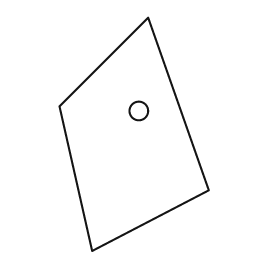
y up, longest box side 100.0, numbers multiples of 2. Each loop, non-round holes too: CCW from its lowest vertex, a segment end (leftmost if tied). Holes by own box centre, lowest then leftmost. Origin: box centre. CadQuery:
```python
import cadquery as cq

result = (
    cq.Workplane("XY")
    .moveTo(-18.0, -50.0)
    .lineTo(32.0, -24.0)
    .lineTo(6.0, 50.0)
    .lineTo(-32.0, 12.0)
    .close()
    .moveTo(2.0, 10.0)
    .circle(4.0)
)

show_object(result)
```